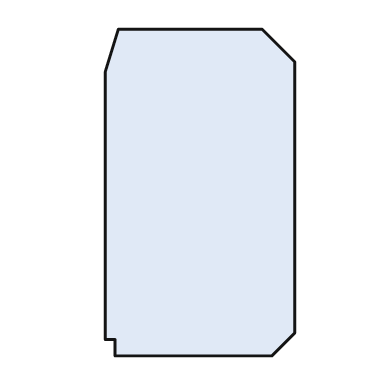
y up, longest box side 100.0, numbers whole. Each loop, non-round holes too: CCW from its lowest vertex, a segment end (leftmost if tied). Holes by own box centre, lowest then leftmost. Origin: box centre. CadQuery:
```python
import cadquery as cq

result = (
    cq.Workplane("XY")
    .moveTo(-26.0, -50.0)
    .lineTo(22.0, -50.0)
    .lineTo(29.0, -43.0)
    .lineTo(29.0, 40.0)
    .lineTo(19.0, 50.0)
    .lineTo(-25.0, 50.0)
    .lineTo(-29.0, 37.0)
    .lineTo(-29.0, -45.0)
    .lineTo(-26.0, -45.0)
    .close()
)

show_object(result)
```